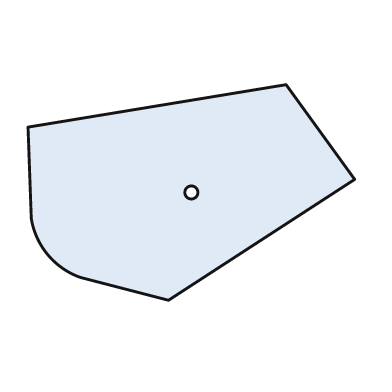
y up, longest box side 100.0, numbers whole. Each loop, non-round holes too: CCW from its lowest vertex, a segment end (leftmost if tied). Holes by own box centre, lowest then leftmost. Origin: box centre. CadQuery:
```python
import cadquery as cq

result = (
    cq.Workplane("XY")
    .moveTo(-7.0, -33.0)
    .lineTo(50.0, 4.0)
    .lineTo(29.0, 33.0)
    .lineTo(-50.0, 20.0)
    .lineTo(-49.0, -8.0)
    .threePointArc((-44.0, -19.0), (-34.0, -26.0))
    .close()
    .moveTo(0.0, 0.0)
    .circle(2.0)
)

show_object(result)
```